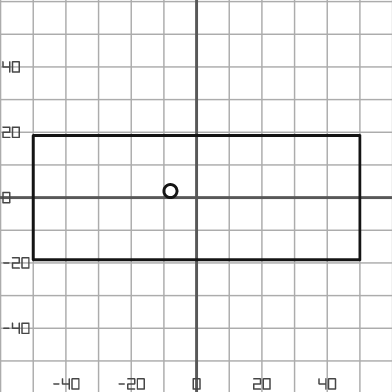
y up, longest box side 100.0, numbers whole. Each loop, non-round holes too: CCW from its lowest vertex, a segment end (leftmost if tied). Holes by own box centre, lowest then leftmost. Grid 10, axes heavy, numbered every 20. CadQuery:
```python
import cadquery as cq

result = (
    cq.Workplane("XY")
    .moveTo(-50.0, -19.0)
    .lineTo(50.0, -19.0)
    .lineTo(50.0, 19.0)
    .lineTo(-50.0, 19.0)
    .close()
    .moveTo(-8.0, 2.0)
    .circle(2.0)
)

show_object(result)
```